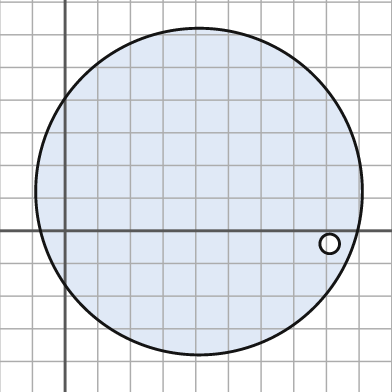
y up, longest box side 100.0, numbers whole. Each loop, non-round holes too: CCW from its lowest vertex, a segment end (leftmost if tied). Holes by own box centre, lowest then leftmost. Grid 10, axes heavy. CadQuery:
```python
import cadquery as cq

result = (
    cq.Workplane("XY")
    .moveTo(41.0, 12.0)
    .circle(50.0)
    .moveTo(81.0, -4.0)
    .circle(3.0)
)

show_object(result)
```